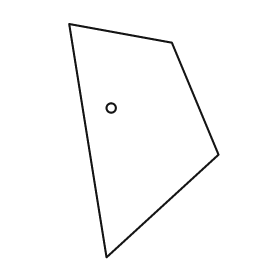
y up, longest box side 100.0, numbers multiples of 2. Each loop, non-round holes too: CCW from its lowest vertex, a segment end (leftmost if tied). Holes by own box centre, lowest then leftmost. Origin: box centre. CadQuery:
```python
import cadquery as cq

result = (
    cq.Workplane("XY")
    .moveTo(-16.0, -50.0)
    .lineTo(32.0, -6.0)
    .lineTo(12.0, 42.0)
    .lineTo(-32.0, 50.0)
    .close()
    .moveTo(-14.0, 14.0)
    .circle(2.0)
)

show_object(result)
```